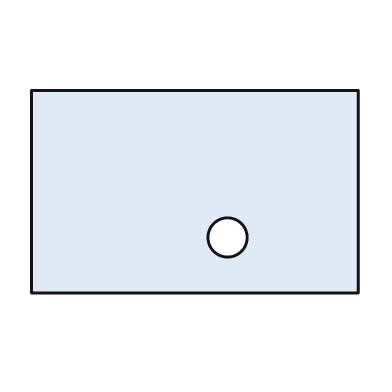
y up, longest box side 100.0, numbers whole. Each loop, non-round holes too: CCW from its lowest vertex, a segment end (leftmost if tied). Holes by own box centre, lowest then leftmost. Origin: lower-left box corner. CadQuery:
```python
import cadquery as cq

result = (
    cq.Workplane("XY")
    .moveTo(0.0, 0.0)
    .lineTo(100.0, 0.0)
    .lineTo(100.0, 62.0)
    .lineTo(0.0, 62.0)
    .close()
    .moveTo(60.0, 17.0)
    .circle(6.0)
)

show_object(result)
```